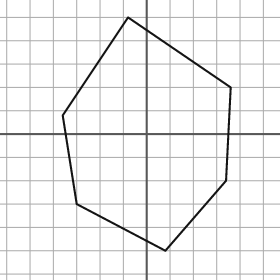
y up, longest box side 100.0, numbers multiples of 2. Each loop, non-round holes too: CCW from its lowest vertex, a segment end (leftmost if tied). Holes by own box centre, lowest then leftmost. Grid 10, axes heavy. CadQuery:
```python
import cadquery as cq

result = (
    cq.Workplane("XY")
    .moveTo(8.0, -50.0)
    .lineTo(34.0, -20.0)
    .lineTo(36.0, 20.0)
    .lineTo(-8.0, 50.0)
    .lineTo(-36.0, 8.0)
    .lineTo(-30.0, -30.0)
    .close()
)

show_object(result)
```